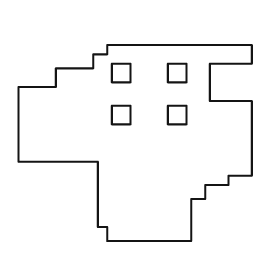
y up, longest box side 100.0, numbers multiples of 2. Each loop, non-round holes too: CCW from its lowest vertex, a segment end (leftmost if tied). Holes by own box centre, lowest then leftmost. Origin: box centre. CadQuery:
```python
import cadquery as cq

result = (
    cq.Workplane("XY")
    .moveTo(-12.0, -42.0)
    .lineTo(24.0, -42.0)
    .lineTo(24.0, -24.0)
    .lineTo(30.0, -24.0)
    .lineTo(30.0, -18.0)
    .lineTo(40.0, -18.0)
    .lineTo(40.0, -14.0)
    .lineTo(50.0, -14.0)
    .lineTo(50.0, 18.0)
    .lineTo(32.0, 18.0)
    .lineTo(32.0, 34.0)
    .lineTo(50.0, 34.0)
    .lineTo(50.0, 42.0)
    .lineTo(-12.0, 42.0)
    .lineTo(-12.0, 38.0)
    .lineTo(-18.0, 38.0)
    .lineTo(-18.0, 32.0)
    .lineTo(-34.0, 32.0)
    .lineTo(-34.0, 24.0)
    .lineTo(-50.0, 24.0)
    .lineTo(-50.0, -8.0)
    .lineTo(-16.0, -8.0)
    .lineTo(-16.0, -36.0)
    .lineTo(-12.0, -36.0)
    .close()
    .moveTo(-10.0, 8.0)
    .lineTo(-2.0, 8.0)
    .lineTo(-2.0, 16.0)
    .lineTo(-10.0, 16.0)
    .close()
    .moveTo(14.0, 8.0)
    .lineTo(22.0, 8.0)
    .lineTo(22.0, 16.0)
    .lineTo(14.0, 16.0)
    .close()
    .moveTo(-10.0, 26.0)
    .lineTo(-2.0, 26.0)
    .lineTo(-2.0, 34.0)
    .lineTo(-10.0, 34.0)
    .close()
    .moveTo(14.0, 26.0)
    .lineTo(22.0, 26.0)
    .lineTo(22.0, 34.0)
    .lineTo(14.0, 34.0)
    .close()
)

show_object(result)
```